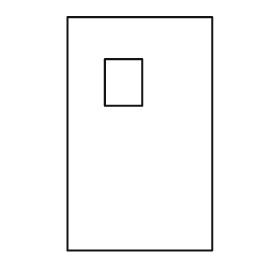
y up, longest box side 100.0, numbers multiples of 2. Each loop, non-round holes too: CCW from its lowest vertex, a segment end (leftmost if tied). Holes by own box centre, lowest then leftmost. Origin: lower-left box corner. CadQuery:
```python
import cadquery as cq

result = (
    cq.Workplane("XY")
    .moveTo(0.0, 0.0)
    .lineTo(62.0, 0.0)
    .lineTo(62.0, 100.0)
    .lineTo(0.0, 100.0)
    .close()
    .moveTo(16.0, 62.0)
    .lineTo(32.0, 62.0)
    .lineTo(32.0, 82.0)
    .lineTo(16.0, 82.0)
    .close()
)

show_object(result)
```